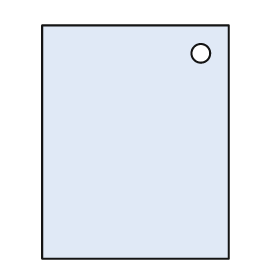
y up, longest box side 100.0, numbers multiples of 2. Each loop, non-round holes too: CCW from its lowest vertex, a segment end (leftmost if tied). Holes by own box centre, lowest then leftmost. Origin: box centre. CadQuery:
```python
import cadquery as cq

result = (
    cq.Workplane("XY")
    .moveTo(-40.0, -50.0)
    .lineTo(40.0, -50.0)
    .lineTo(40.0, 50.0)
    .lineTo(-40.0, 50.0)
    .close()
    .moveTo(28.0, 38.0)
    .circle(4.0)
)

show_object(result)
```